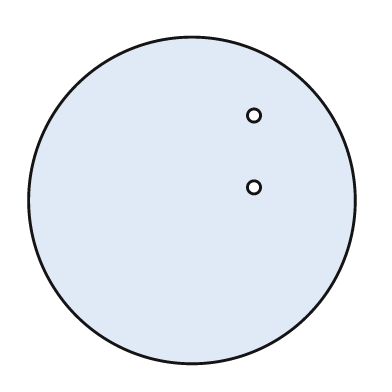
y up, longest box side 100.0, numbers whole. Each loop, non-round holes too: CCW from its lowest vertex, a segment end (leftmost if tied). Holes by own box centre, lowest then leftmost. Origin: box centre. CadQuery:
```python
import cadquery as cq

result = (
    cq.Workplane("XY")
    .moveTo(0.0, 0.0)
    .circle(50.0)
    .moveTo(19.0, 4.0)
    .circle(2.0)
    .moveTo(19.0, 26.0)
    .circle(2.0)
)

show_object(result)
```